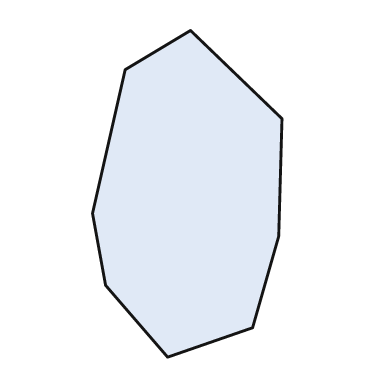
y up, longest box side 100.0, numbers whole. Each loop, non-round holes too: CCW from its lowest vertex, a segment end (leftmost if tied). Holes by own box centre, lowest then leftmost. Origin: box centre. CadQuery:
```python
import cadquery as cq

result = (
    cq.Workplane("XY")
    .moveTo(-6.0, -50.0)
    .lineTo(20.0, -41.0)
    .lineTo(28.0, -13.0)
    .lineTo(29.0, 23.0)
    .lineTo(1.0, 50.0)
    .lineTo(-19.0, 38.0)
    .lineTo(-29.0, -6.0)
    .lineTo(-25.0, -28.0)
    .close()
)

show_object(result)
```